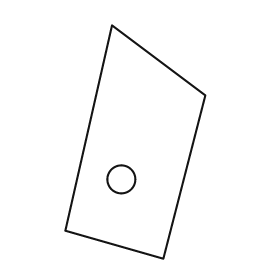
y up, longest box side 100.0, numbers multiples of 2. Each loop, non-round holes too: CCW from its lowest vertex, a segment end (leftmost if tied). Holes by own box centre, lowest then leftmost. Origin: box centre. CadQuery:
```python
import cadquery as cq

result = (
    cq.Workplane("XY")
    .moveTo(12.0, -50.0)
    .lineTo(30.0, 20.0)
    .lineTo(-10.0, 50.0)
    .lineTo(-30.0, -38.0)
    .close()
    .moveTo(-6.0, -16.0)
    .circle(6.0)
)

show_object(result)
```